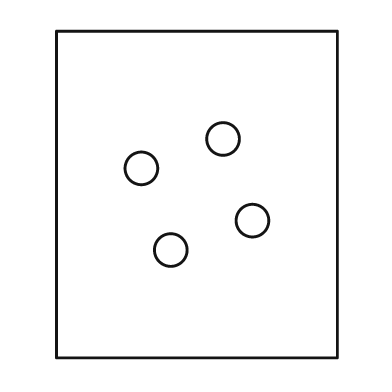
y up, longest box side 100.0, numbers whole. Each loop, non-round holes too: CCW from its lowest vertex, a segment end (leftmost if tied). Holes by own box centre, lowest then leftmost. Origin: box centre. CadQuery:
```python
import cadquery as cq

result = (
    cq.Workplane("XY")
    .moveTo(-43.0, -50.0)
    .lineTo(43.0, -50.0)
    .lineTo(43.0, 50.0)
    .lineTo(-43.0, 50.0)
    .close()
    .moveTo(-8.0, -17.0)
    .circle(5.0)
    .moveTo(17.0, -8.0)
    .circle(5.0)
    .moveTo(-17.0, 8.0)
    .circle(5.0)
    .moveTo(8.0, 17.0)
    .circle(5.0)
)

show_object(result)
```